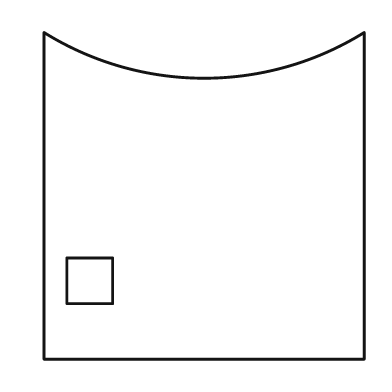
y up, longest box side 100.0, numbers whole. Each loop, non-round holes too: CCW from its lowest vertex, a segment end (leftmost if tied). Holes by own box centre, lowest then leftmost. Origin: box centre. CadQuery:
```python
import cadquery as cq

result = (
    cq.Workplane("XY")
    .moveTo(-49.0, -50.0)
    .lineTo(49.0, -50.0)
    .lineTo(49.0, 50.0)
    .threePointArc((0.0, 36.0), (-49.0, 50.0))
    .close()
    .moveTo(-42.0, -33.0)
    .lineTo(-28.0, -33.0)
    .lineTo(-28.0, -19.0)
    .lineTo(-42.0, -19.0)
    .close()
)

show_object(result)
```